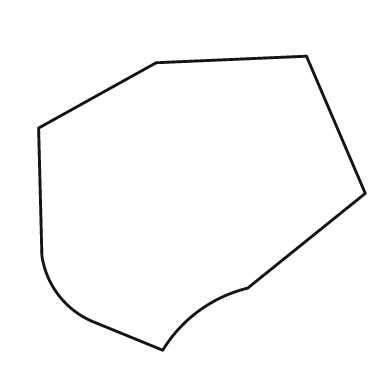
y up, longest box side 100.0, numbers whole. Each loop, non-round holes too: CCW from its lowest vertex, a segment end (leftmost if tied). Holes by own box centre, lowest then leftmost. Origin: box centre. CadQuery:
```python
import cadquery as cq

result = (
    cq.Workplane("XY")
    .moveTo(-12.0, -45.0)
    .threePointArc((-1.0, -33.0), (14.0, -26.0))
    .lineTo(50.0, 3.0)
    .lineTo(32.0, 45.0)
    .lineTo(-14.0, 43.0)
    .lineTo(-50.0, 23.0)
    .lineTo(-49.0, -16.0)
    .threePointArc((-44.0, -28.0), (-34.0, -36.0))
    .close()
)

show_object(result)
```